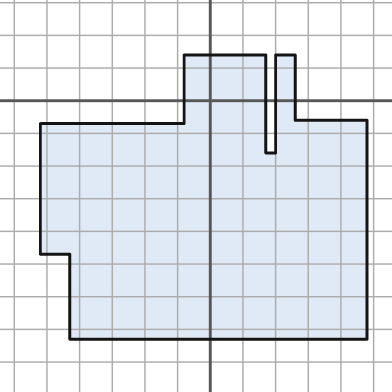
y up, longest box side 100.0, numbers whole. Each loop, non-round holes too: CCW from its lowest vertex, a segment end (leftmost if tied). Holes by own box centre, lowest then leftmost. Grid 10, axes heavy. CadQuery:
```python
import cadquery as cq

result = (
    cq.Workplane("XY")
    .moveTo(-43.0, -73.0)
    .lineTo(48.0, -73.0)
    .lineTo(48.0, -6.0)
    .lineTo(26.0, -6.0)
    .lineTo(26.0, 14.0)
    .lineTo(20.0, 14.0)
    .lineTo(20.0, -16.0)
    .lineTo(17.0, -16.0)
    .lineTo(17.0, 14.0)
    .lineTo(-8.0, 14.0)
    .lineTo(-8.0, -7.0)
    .lineTo(-52.0, -7.0)
    .lineTo(-52.0, -47.0)
    .lineTo(-43.0, -47.0)
    .close()
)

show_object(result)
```